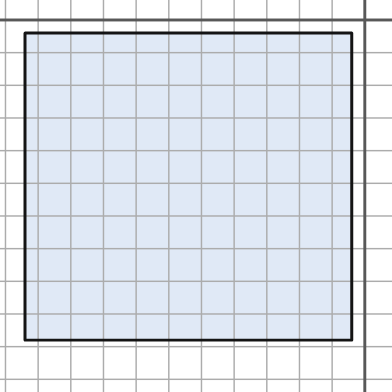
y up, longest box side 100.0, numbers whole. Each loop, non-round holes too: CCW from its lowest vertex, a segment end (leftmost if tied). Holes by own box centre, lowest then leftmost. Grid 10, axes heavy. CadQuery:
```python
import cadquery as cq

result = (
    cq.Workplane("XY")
    .moveTo(-104.0, -98.0)
    .lineTo(-4.0, -98.0)
    .lineTo(-4.0, -4.0)
    .lineTo(-104.0, -4.0)
    .close()
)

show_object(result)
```